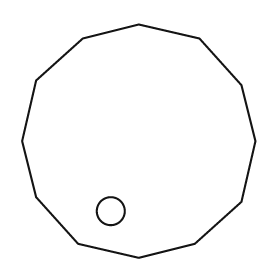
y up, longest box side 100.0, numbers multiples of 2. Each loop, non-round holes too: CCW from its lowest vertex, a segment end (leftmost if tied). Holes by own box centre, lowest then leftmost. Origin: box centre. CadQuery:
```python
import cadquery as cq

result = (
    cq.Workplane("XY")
    .moveTo(0.0, -50.0)
    .lineTo(24.0, -44.0)
    .lineTo(44.0, -26.0)
    .lineTo(50.0, 0.0)
    .lineTo(44.0, 24.0)
    .lineTo(26.0, 44.0)
    .lineTo(0.0, 50.0)
    .lineTo(-24.0, 44.0)
    .lineTo(-44.0, 26.0)
    .lineTo(-50.0, 0.0)
    .lineTo(-44.0, -24.0)
    .lineTo(-26.0, -44.0)
    .close()
    .moveTo(-12.0, -30.0)
    .circle(6.0)
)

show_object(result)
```